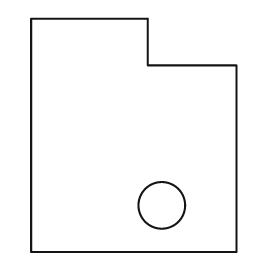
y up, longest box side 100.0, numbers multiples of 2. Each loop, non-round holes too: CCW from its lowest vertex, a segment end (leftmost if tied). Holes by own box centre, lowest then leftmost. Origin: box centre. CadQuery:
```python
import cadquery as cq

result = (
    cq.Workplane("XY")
    .moveTo(-44.0, -50.0)
    .lineTo(44.0, -50.0)
    .lineTo(44.0, 30.0)
    .lineTo(6.0, 30.0)
    .lineTo(6.0, 50.0)
    .lineTo(-44.0, 50.0)
    .close()
    .moveTo(12.0, -30.0)
    .circle(10.0)
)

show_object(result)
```